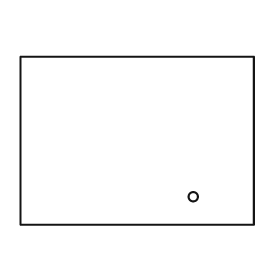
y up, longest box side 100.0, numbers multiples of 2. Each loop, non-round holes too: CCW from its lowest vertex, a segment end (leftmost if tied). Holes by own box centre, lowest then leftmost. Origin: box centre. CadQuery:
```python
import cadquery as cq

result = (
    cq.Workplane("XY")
    .moveTo(-50.0, -36.0)
    .lineTo(50.0, -36.0)
    .lineTo(50.0, 36.0)
    .lineTo(-50.0, 36.0)
    .close()
    .moveTo(24.0, -24.0)
    .circle(2.0)
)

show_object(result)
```